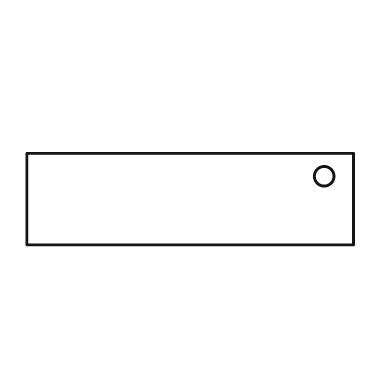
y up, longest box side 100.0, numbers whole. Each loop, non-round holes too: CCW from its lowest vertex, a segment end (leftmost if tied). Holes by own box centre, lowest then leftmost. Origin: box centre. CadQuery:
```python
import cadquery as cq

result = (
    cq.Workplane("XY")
    .moveTo(-50.0, -14.0)
    .lineTo(50.0, -14.0)
    .lineTo(50.0, 14.0)
    .lineTo(-50.0, 14.0)
    .close()
    .moveTo(41.0, 7.0)
    .circle(3.0)
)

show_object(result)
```